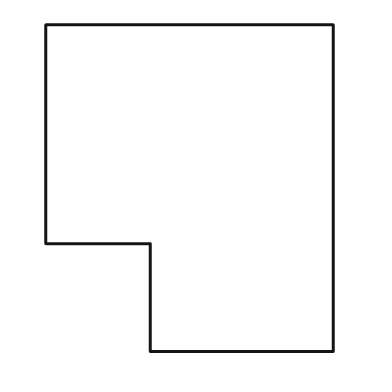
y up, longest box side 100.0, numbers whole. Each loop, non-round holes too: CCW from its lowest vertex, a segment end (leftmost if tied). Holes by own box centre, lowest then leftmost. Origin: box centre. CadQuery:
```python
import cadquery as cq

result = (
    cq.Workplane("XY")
    .moveTo(-12.0, -50.0)
    .lineTo(44.0, -50.0)
    .lineTo(44.0, 50.0)
    .lineTo(-44.0, 50.0)
    .lineTo(-44.0, -17.0)
    .lineTo(-12.0, -17.0)
    .close()
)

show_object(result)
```